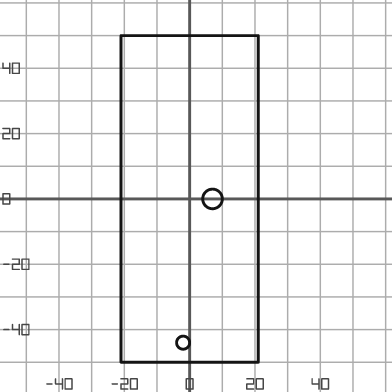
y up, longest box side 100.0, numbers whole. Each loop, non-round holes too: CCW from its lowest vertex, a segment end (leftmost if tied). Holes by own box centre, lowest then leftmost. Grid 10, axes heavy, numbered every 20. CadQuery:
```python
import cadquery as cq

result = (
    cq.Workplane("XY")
    .moveTo(-21.0, -50.0)
    .lineTo(21.0, -50.0)
    .lineTo(21.0, 50.0)
    .lineTo(-21.0, 50.0)
    .close()
    .moveTo(-2.0, -44.0)
    .circle(2.0)
    .moveTo(7.0, 0.0)
    .circle(3.0)
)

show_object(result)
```